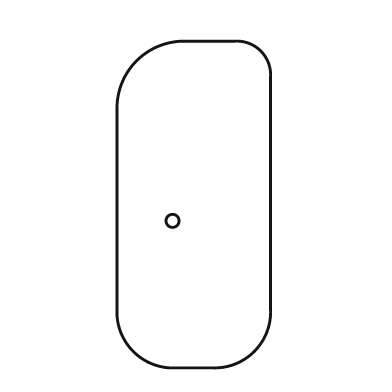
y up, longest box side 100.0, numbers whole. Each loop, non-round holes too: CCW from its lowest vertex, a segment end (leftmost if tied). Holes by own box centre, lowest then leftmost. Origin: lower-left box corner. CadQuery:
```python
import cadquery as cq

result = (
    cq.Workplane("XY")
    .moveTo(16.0, 0.0)
    .lineTo(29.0, 0.0)
    .threePointArc((42.0, 5.0), (47.0, 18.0))
    .lineTo(47.0, 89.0)
    .threePointArc((44.0, 97.0), (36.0, 100.0))
    .lineTo(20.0, 100.0)
    .threePointArc((6.0, 94.0), (0.0, 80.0))
    .lineTo(0.0, 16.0)
    .threePointArc((5.0, 5.0), (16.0, 0.0))
    .close()
    .moveTo(17.0, 45.0)
    .circle(2.0)
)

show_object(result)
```